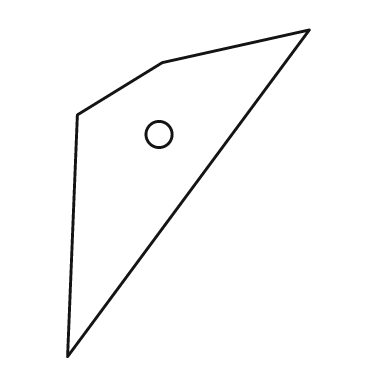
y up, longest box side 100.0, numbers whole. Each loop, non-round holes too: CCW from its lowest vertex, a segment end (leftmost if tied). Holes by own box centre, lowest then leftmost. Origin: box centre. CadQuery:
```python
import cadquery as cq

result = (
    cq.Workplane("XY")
    .moveTo(-37.0, -50.0)
    .lineTo(37.0, 50.0)
    .lineTo(-8.0, 40.0)
    .lineTo(-34.0, 24.0)
    .close()
    .moveTo(-9.0, 18.0)
    .circle(4.0)
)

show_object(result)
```